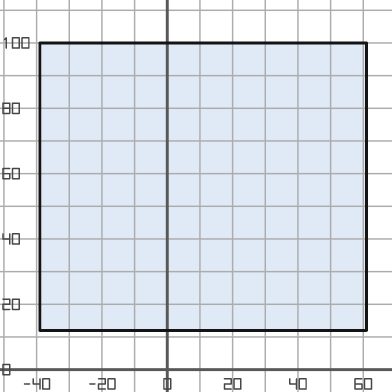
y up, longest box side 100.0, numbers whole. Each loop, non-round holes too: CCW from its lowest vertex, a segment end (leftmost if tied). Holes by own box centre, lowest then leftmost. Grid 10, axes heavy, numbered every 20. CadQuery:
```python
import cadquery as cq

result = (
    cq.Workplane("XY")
    .moveTo(-39.0, 12.0)
    .lineTo(61.0, 12.0)
    .lineTo(61.0, 100.0)
    .lineTo(-39.0, 100.0)
    .close()
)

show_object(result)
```